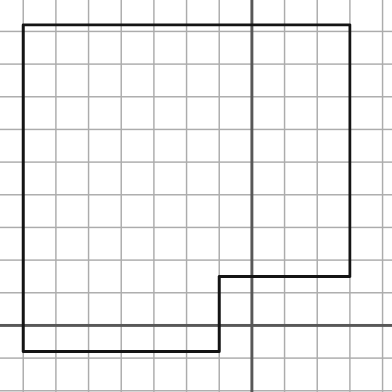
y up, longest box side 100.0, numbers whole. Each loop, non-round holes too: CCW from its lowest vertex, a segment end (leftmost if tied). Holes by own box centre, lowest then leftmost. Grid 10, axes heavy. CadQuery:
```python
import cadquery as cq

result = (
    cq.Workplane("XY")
    .moveTo(-70.0, -8.0)
    .lineTo(-10.0, -8.0)
    .lineTo(-10.0, 15.0)
    .lineTo(30.0, 15.0)
    .lineTo(30.0, 92.0)
    .lineTo(-70.0, 92.0)
    .close()
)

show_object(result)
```